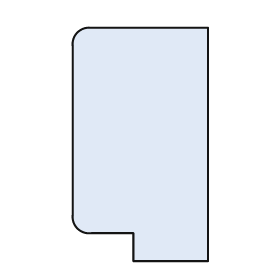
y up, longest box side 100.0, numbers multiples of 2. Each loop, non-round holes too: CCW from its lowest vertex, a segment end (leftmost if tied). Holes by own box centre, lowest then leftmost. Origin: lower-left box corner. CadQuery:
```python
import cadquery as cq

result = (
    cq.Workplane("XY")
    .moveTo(26.0, 0.0)
    .lineTo(58.0, 0.0)
    .lineTo(58.0, 100.0)
    .lineTo(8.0, 100.0)
    .threePointArc((2.0, 98.0), (0.0, 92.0))
    .lineTo(0.0, 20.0)
    .threePointArc((2.0, 14.0), (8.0, 12.0))
    .lineTo(26.0, 12.0)
    .close()
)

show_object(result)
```